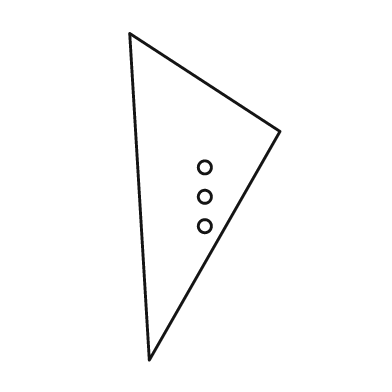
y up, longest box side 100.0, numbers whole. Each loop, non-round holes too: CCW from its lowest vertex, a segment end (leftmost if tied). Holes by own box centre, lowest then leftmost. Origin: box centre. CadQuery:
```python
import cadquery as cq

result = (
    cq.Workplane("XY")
    .moveTo(-17.0, -50.0)
    .lineTo(23.0, 20.0)
    .lineTo(-23.0, 50.0)
    .close()
    .moveTo(0.0, -9.0)
    .circle(2.0)
    .moveTo(0.0, 0.0)
    .circle(2.0)
    .moveTo(0.0, 9.0)
    .circle(2.0)
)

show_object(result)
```